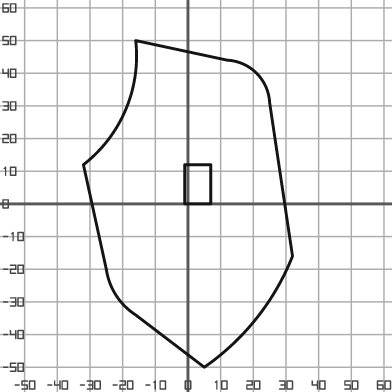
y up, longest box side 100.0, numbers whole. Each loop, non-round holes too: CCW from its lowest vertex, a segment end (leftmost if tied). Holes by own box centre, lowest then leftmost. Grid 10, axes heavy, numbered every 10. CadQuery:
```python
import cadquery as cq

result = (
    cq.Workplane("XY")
    .moveTo(5.0, -50.0)
    .threePointArc((21.0, -35.0), (32.0, -16.0))
    .lineTo(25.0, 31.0)
    .threePointArc((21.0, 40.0), (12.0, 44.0))
    .lineTo(-16.0, 50.0)
    .threePointArc((-19.0, 29.0), (-32.0, 12.0))
    .lineTo(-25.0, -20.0)
    .threePointArc((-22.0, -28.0), (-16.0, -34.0))
    .close()
    .moveTo(-1.0, 0.0)
    .lineTo(7.0, 0.0)
    .lineTo(7.0, 12.0)
    .lineTo(-1.0, 12.0)
    .close()
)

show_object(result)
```